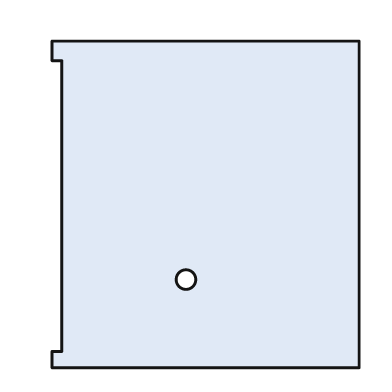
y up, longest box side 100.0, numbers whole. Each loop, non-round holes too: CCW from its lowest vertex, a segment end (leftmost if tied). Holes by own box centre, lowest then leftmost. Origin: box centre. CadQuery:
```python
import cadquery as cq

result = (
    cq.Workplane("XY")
    .moveTo(-47.0, -50.0)
    .lineTo(47.0, -50.0)
    .lineTo(47.0, 50.0)
    .lineTo(-47.0, 50.0)
    .lineTo(-47.0, 44.0)
    .lineTo(-44.0, 44.0)
    .lineTo(-44.0, -45.0)
    .lineTo(-47.0, -45.0)
    .close()
    .moveTo(-6.0, -23.0)
    .circle(3.0)
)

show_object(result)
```